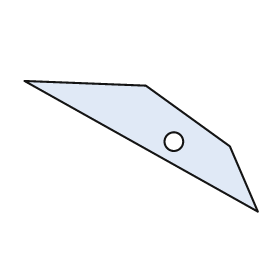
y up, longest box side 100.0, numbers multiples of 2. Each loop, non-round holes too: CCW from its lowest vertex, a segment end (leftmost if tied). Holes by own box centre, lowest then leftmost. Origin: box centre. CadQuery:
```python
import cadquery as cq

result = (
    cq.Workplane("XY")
    .moveTo(50.0, -28.0)
    .lineTo(38.0, 0.0)
    .lineTo(2.0, 26.0)
    .lineTo(-50.0, 28.0)
    .close()
    .moveTo(14.0, 2.0)
    .circle(4.0)
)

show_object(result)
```